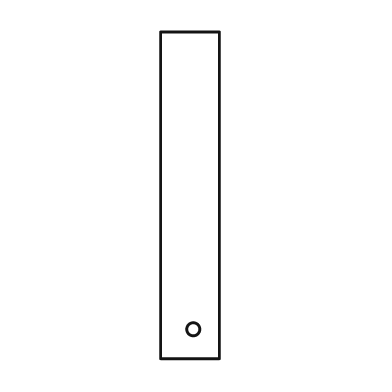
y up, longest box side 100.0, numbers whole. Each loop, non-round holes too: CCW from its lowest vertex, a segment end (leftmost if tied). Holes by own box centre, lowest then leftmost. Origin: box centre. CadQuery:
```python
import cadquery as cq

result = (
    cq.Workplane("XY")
    .moveTo(-9.0, -50.0)
    .lineTo(9.0, -50.0)
    .lineTo(9.0, 50.0)
    .lineTo(-9.0, 50.0)
    .close()
    .moveTo(1.0, -41.0)
    .circle(2.0)
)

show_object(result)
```